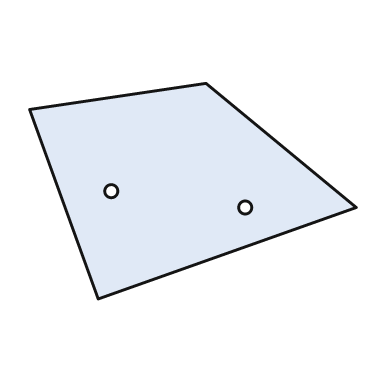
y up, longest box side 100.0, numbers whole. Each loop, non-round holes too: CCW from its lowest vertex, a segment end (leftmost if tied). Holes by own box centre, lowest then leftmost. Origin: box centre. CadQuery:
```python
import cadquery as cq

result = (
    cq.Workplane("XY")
    .moveTo(-29.0, -33.0)
    .lineTo(50.0, -5.0)
    .lineTo(4.0, 33.0)
    .lineTo(-50.0, 25.0)
    .close()
    .moveTo(16.0, -5.0)
    .circle(2.0)
    .moveTo(-25.0, 0.0)
    .circle(2.0)
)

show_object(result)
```